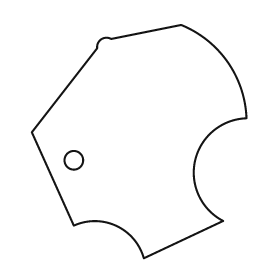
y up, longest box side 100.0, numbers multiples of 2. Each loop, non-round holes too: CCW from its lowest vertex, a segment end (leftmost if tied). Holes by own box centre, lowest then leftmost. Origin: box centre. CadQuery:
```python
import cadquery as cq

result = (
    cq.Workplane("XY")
    .moveTo(2.0, -50.0)
    .lineTo(36.0, -34.0)
    .threePointArc((24.0, -8.0), (46.0, 10.0))
    .threePointArc((38.0, 34.0), (18.0, 50.0))
    .lineTo(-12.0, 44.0)
    .threePointArc((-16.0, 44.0), (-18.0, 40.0))
    .lineTo(-46.0, 4.0)
    .lineTo(-28.0, -36.0)
    .threePointArc((-10.0, -36.0), (2.0, -50.0))
    .close()
    .moveTo(-28.0, -8.0)
    .circle(4.0)
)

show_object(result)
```